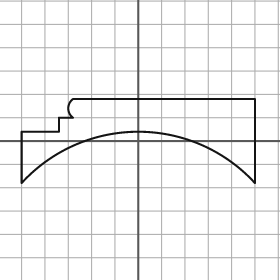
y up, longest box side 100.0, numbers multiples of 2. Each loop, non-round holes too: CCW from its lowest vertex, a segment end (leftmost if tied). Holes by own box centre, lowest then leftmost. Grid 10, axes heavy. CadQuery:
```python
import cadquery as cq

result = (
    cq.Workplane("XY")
    .moveTo(-50.0, -18.0)
    .threePointArc((0.0, 4.0), (50.0, -18.0))
    .lineTo(50.0, 18.0)
    .lineTo(-28.0, 18.0)
    .threePointArc((-30.0, 14.0), (-28.0, 10.0))
    .lineTo(-34.0, 10.0)
    .lineTo(-34.0, 4.0)
    .lineTo(-50.0, 4.0)
    .close()
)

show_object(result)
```